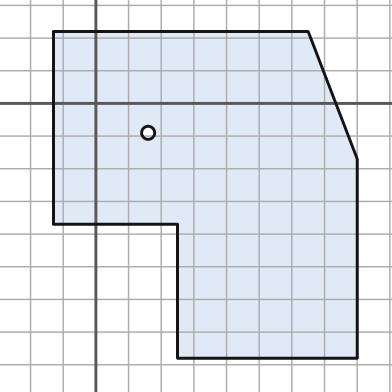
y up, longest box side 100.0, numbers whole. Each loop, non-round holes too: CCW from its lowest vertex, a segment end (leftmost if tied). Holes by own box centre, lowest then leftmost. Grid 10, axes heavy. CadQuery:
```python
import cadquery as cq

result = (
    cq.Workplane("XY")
    .moveTo(25.0, -78.0)
    .lineTo(80.0, -78.0)
    .lineTo(80.0, -17.0)
    .lineTo(65.0, 22.0)
    .lineTo(-13.0, 22.0)
    .lineTo(-13.0, -37.0)
    .lineTo(25.0, -37.0)
    .close()
    .moveTo(16.0, -9.0)
    .circle(2.0)
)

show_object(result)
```